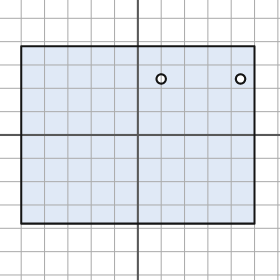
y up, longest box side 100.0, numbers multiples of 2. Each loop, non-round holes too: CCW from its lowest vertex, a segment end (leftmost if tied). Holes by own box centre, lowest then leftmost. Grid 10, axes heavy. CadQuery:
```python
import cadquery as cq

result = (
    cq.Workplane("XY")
    .moveTo(-50.0, -38.0)
    .lineTo(50.0, -38.0)
    .lineTo(50.0, 38.0)
    .lineTo(-50.0, 38.0)
    .close()
    .moveTo(10.0, 24.0)
    .circle(2.0)
    .moveTo(44.0, 24.0)
    .circle(2.0)
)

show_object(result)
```